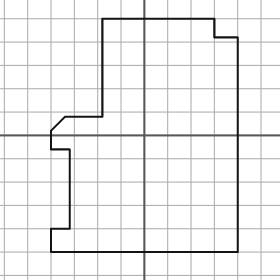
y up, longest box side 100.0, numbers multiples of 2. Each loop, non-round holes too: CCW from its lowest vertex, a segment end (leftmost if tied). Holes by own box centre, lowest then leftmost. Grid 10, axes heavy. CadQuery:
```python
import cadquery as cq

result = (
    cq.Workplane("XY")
    .moveTo(-40.0, -50.0)
    .lineTo(40.0, -50.0)
    .lineTo(40.0, 42.0)
    .lineTo(30.0, 42.0)
    .lineTo(30.0, 50.0)
    .lineTo(-18.0, 50.0)
    .lineTo(-18.0, 8.0)
    .lineTo(-34.0, 8.0)
    .lineTo(-40.0, 2.0)
    .lineTo(-40.0, -6.0)
    .lineTo(-32.0, -6.0)
    .lineTo(-32.0, -40.0)
    .lineTo(-40.0, -40.0)
    .close()
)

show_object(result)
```